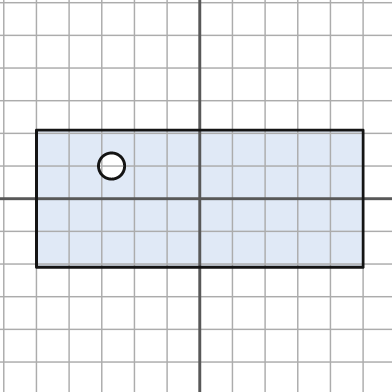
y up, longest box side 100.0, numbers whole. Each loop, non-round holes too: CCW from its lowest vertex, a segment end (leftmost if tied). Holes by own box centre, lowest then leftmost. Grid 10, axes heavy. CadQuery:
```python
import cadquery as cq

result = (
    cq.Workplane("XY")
    .moveTo(-50.0, -21.0)
    .lineTo(50.0, -21.0)
    .lineTo(50.0, 21.0)
    .lineTo(-50.0, 21.0)
    .close()
    .moveTo(-27.0, 10.0)
    .circle(4.0)
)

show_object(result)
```